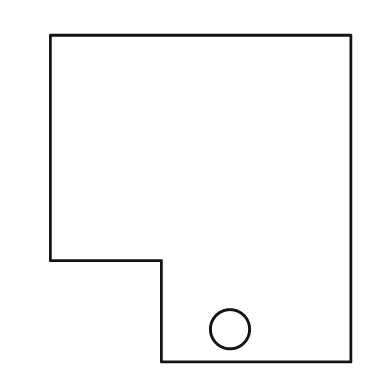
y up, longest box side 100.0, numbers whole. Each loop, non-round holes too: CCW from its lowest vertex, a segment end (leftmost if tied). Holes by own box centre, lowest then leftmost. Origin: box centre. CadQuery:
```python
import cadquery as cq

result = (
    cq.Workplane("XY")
    .moveTo(-12.0, -50.0)
    .lineTo(46.0, -50.0)
    .lineTo(46.0, 50.0)
    .lineTo(-46.0, 50.0)
    .lineTo(-46.0, -19.0)
    .lineTo(-12.0, -19.0)
    .close()
    .moveTo(9.0, -40.0)
    .circle(6.0)
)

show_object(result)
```